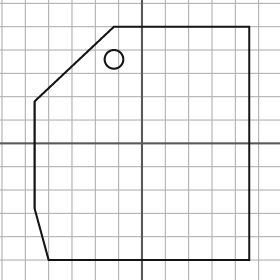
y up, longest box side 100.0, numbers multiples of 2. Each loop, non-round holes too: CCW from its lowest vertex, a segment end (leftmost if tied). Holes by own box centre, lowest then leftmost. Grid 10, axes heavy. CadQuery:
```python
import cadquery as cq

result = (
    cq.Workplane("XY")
    .moveTo(-40.0, -50.0)
    .lineTo(46.0, -50.0)
    .lineTo(46.0, 50.0)
    .lineTo(-12.0, 50.0)
    .lineTo(-46.0, 18.0)
    .lineTo(-46.0, -28.0)
    .close()
    .moveTo(-12.0, 36.0)
    .circle(4.0)
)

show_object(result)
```